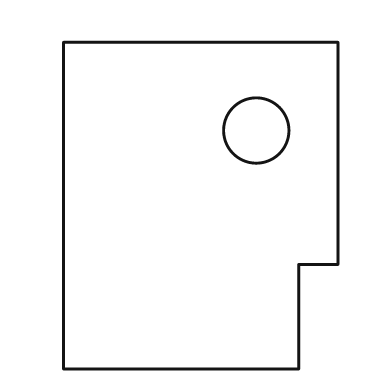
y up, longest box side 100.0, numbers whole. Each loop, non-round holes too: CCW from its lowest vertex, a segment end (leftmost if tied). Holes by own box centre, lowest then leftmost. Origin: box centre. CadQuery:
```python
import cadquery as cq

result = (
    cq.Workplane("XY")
    .moveTo(-42.0, -50.0)
    .lineTo(30.0, -50.0)
    .lineTo(30.0, -18.0)
    .lineTo(42.0, -18.0)
    .lineTo(42.0, 50.0)
    .lineTo(-42.0, 50.0)
    .close()
    .moveTo(17.0, 23.0)
    .circle(10.0)
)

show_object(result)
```